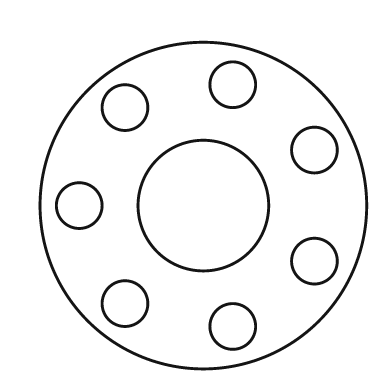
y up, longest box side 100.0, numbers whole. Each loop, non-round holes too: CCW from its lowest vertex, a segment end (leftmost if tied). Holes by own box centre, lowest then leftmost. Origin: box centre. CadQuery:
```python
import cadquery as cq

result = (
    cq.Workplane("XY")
    .moveTo(0.0, 0.0)
    .circle(50.0)
    .moveTo(9.0, -37.0)
    .circle(7.0)
    .moveTo(-24.0, -30.0)
    .circle(7.0)
    .moveTo(34.0, -17.0)
    .circle(7.0)
    .moveTo(-38.0, 0.0)
    .circle(7.0)
    .moveTo(0.0, 0.0)
    .circle(20.0)
    .moveTo(34.0, 17.0)
    .circle(7.0)
    .moveTo(-24.0, 30.0)
    .circle(7.0)
    .moveTo(9.0, 37.0)
    .circle(7.0)
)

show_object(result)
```